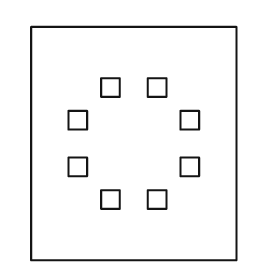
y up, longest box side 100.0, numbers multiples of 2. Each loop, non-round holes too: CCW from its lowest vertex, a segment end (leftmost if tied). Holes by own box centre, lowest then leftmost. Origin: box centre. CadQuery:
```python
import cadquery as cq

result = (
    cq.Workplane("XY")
    .moveTo(-44.0, -50.0)
    .lineTo(44.0, -50.0)
    .lineTo(44.0, 50.0)
    .lineTo(-44.0, 50.0)
    .close()
    .moveTo(-14.0, -28.0)
    .lineTo(-6.0, -28.0)
    .lineTo(-6.0, -20.0)
    .lineTo(-14.0, -20.0)
    .close()
    .moveTo(6.0, -28.0)
    .lineTo(14.0, -28.0)
    .lineTo(14.0, -20.0)
    .lineTo(6.0, -20.0)
    .close()
    .moveTo(-28.0, -14.0)
    .lineTo(-20.0, -14.0)
    .lineTo(-20.0, -6.0)
    .lineTo(-28.0, -6.0)
    .close()
    .moveTo(20.0, -14.0)
    .lineTo(28.0, -14.0)
    .lineTo(28.0, -6.0)
    .lineTo(20.0, -6.0)
    .close()
    .moveTo(-28.0, 6.0)
    .lineTo(-20.0, 6.0)
    .lineTo(-20.0, 14.0)
    .lineTo(-28.0, 14.0)
    .close()
    .moveTo(20.0, 6.0)
    .lineTo(28.0, 6.0)
    .lineTo(28.0, 14.0)
    .lineTo(20.0, 14.0)
    .close()
    .moveTo(-14.0, 20.0)
    .lineTo(-6.0, 20.0)
    .lineTo(-6.0, 28.0)
    .lineTo(-14.0, 28.0)
    .close()
    .moveTo(6.0, 20.0)
    .lineTo(14.0, 20.0)
    .lineTo(14.0, 28.0)
    .lineTo(6.0, 28.0)
    .close()
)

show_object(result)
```